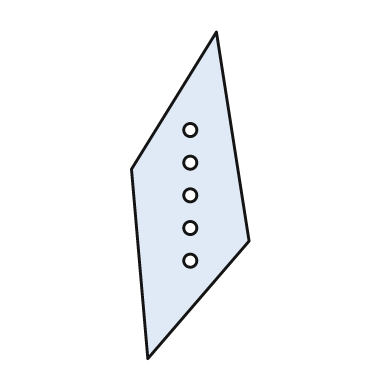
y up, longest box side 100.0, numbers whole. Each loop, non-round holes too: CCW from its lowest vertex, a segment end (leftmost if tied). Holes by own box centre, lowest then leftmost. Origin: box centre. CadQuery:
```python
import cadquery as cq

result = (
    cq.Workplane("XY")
    .moveTo(-13.0, -50.0)
    .lineTo(18.0, -14.0)
    .lineTo(8.0, 50.0)
    .lineTo(-18.0, 8.0)
    .close()
    .moveTo(0.0, -20.0)
    .circle(2.0)
    .moveTo(0.0, -10.0)
    .circle(2.0)
    .moveTo(0.0, 0.0)
    .circle(2.0)
    .moveTo(0.0, 10.0)
    .circle(2.0)
    .moveTo(0.0, 20.0)
    .circle(2.0)
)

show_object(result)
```